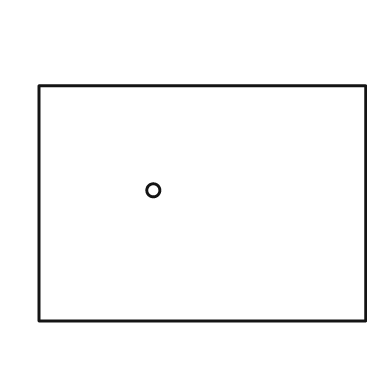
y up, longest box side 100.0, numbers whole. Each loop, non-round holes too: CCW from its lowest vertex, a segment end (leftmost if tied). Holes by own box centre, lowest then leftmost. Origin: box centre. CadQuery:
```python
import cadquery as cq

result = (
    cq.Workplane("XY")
    .moveTo(-50.0, -36.0)
    .lineTo(50.0, -36.0)
    .lineTo(50.0, 36.0)
    .lineTo(-50.0, 36.0)
    .close()
    .moveTo(-15.0, 4.0)
    .circle(2.0)
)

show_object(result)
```